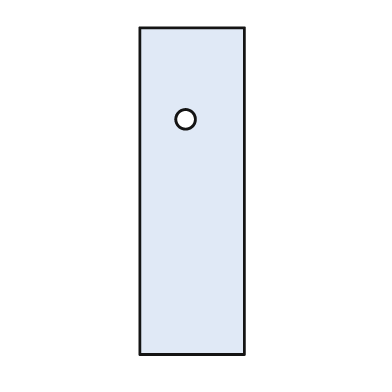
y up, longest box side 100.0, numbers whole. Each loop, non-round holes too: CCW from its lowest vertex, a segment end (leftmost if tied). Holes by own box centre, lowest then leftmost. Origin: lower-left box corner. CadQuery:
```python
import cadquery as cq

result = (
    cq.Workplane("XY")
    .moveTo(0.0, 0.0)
    .lineTo(32.0, 0.0)
    .lineTo(32.0, 100.0)
    .lineTo(0.0, 100.0)
    .close()
    .moveTo(14.0, 72.0)
    .circle(3.0)
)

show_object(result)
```